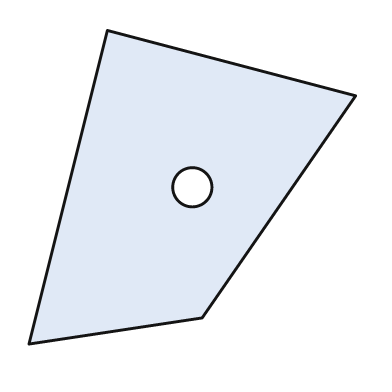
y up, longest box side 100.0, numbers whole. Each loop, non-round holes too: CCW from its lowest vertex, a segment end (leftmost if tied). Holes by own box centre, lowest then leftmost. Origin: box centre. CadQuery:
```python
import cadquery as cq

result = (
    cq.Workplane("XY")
    .moveTo(-50.0, -48.0)
    .lineTo(3.0, -40.0)
    .lineTo(50.0, 28.0)
    .lineTo(-26.0, 48.0)
    .close()
    .moveTo(0.0, 0.0)
    .circle(6.0)
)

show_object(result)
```